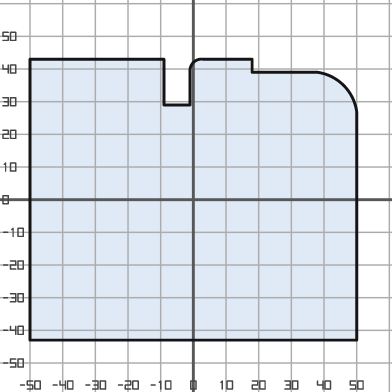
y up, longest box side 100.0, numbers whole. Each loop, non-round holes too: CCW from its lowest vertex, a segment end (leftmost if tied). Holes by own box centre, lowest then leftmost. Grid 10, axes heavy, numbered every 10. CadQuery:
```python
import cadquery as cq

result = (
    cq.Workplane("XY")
    .moveTo(-50.0, -43.0)
    .lineTo(50.0, -43.0)
    .lineTo(50.0, 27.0)
    .threePointArc((46.0, 35.0), (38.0, 39.0))
    .lineTo(18.0, 39.0)
    .lineTo(18.0, 43.0)
    .lineTo(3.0, 43.0)
    .threePointArc((0.0, 42.0), (-1.0, 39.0))
    .lineTo(-1.0, 29.0)
    .lineTo(-9.0, 29.0)
    .lineTo(-9.0, 43.0)
    .lineTo(-50.0, 43.0)
    .close()
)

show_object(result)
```